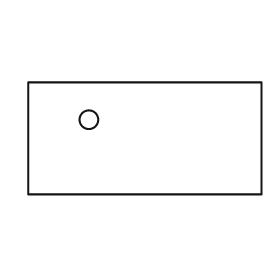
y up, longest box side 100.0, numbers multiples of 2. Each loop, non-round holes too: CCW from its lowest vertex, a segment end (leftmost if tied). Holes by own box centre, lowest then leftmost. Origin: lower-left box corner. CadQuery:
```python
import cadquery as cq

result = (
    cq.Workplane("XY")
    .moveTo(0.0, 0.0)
    .lineTo(100.0, 0.0)
    .lineTo(100.0, 48.0)
    .lineTo(0.0, 48.0)
    .close()
    .moveTo(26.0, 32.0)
    .circle(4.0)
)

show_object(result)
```